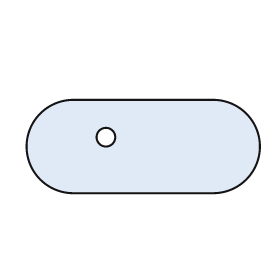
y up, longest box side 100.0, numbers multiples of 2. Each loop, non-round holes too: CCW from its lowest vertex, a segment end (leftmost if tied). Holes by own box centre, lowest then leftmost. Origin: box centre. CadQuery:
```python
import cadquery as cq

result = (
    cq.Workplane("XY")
    .moveTo(-30.0, -20.0)
    .lineTo(30.0, -20.0)
    .threePointArc((50.0, 0.0), (30.0, 20.0))
    .lineTo(-30.0, 20.0)
    .threePointArc((-50.0, 0.0), (-30.0, -20.0))
    .close()
    .moveTo(-16.0, 4.0)
    .circle(4.0)
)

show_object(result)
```